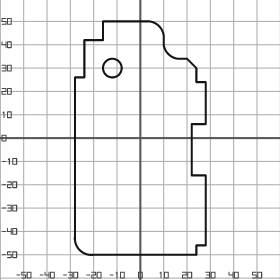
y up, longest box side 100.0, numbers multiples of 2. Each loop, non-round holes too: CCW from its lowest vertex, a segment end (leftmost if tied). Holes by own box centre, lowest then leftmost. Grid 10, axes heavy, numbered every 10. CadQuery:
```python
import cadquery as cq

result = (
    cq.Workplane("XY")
    .moveTo(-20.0, -50.0)
    .lineTo(24.0, -50.0)
    .lineTo(24.0, -46.0)
    .lineTo(28.0, -46.0)
    .lineTo(28.0, -16.0)
    .lineTo(22.0, -16.0)
    .lineTo(22.0, 6.0)
    .lineTo(28.0, 6.0)
    .lineTo(28.0, 24.0)
    .lineTo(24.0, 24.0)
    .lineTo(24.0, 30.0)
    .lineTo(20.0, 34.0)
    .lineTo(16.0, 34.0)
    .threePointArc((12.0, 36.0), (10.0, 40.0))
    .lineTo(10.0, 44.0)
    .threePointArc((8.0, 48.0), (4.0, 50.0))
    .lineTo(-16.0, 50.0)
    .lineTo(-16.0, 42.0)
    .lineTo(-24.0, 42.0)
    .lineTo(-24.0, 26.0)
    .lineTo(-28.0, 26.0)
    .lineTo(-28.0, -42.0)
    .threePointArc((-26.0, -48.0), (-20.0, -50.0))
    .close()
    .moveTo(-12.0, 30.0)
    .circle(4.0)
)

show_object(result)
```